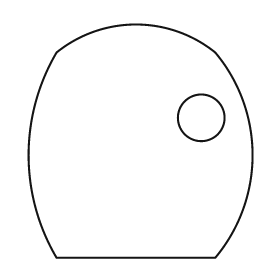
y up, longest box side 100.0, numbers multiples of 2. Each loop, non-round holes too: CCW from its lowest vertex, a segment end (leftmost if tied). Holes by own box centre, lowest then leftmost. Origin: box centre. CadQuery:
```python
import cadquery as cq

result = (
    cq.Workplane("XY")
    .moveTo(-36.0, -50.0)
    .lineTo(32.0, -50.0)
    .threePointArc((48.0, -6.0), (32.0, 38.0))
    .threePointArc((-2.0, 50.0), (-36.0, 38.0))
    .threePointArc((-48.0, -6.0), (-36.0, -50.0))
    .close()
    .moveTo(26.0, 10.0)
    .circle(10.0)
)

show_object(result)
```